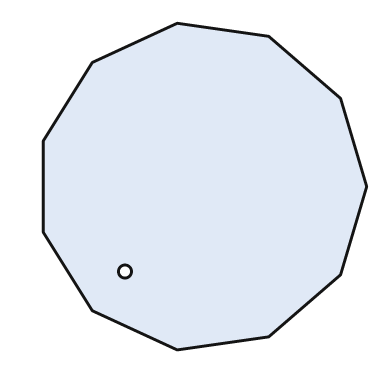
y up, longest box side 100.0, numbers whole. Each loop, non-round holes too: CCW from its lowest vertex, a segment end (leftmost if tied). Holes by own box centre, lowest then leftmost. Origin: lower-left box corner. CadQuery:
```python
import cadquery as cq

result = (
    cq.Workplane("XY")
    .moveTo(41.0, 0.0)
    .lineTo(69.0, 4.0)
    .lineTo(91.0, 23.0)
    .lineTo(99.0, 50.0)
    .lineTo(91.0, 77.0)
    .lineTo(69.0, 96.0)
    .lineTo(41.0, 100.0)
    .lineTo(15.0, 88.0)
    .lineTo(0.0, 64.0)
    .lineTo(0.0, 36.0)
    .lineTo(15.0, 12.0)
    .close()
    .moveTo(25.0, 24.0)
    .circle(2.0)
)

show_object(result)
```